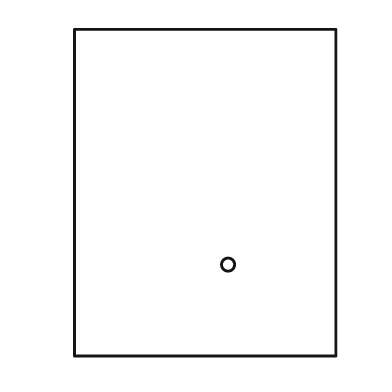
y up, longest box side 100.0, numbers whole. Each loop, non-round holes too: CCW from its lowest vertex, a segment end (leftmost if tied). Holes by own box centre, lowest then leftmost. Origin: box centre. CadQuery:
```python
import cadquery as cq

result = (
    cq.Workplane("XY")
    .moveTo(-40.0, -50.0)
    .lineTo(40.0, -50.0)
    .lineTo(40.0, 50.0)
    .lineTo(-40.0, 50.0)
    .close()
    .moveTo(7.0, -22.0)
    .circle(2.0)
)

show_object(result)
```